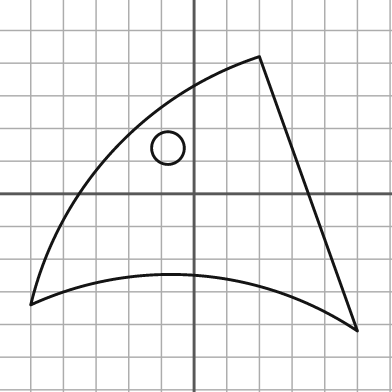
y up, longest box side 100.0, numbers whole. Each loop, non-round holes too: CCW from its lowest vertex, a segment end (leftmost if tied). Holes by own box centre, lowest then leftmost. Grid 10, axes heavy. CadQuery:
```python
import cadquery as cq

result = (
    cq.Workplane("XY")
    .moveTo(50.0, -42.0)
    .lineTo(20.0, 42.0)
    .threePointArc((-25.0, 13.0), (-50.0, -34.0))
    .threePointArc((1.0, -25.0), (50.0, -42.0))
    .close()
    .moveTo(-8.0, 14.0)
    .circle(5.0)
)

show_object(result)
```